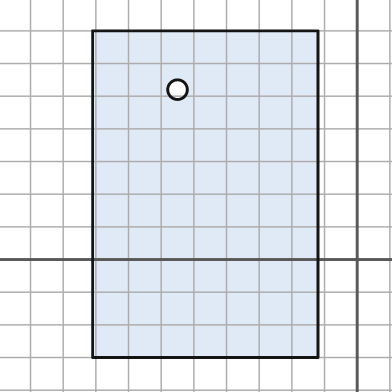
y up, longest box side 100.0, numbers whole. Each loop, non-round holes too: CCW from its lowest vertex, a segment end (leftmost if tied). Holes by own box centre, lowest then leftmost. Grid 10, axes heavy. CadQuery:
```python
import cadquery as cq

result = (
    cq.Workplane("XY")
    .moveTo(-81.0, -30.0)
    .lineTo(-12.0, -30.0)
    .lineTo(-12.0, 70.0)
    .lineTo(-81.0, 70.0)
    .close()
    .moveTo(-55.0, 52.0)
    .circle(3.0)
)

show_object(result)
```